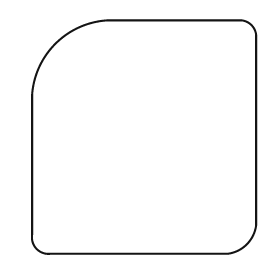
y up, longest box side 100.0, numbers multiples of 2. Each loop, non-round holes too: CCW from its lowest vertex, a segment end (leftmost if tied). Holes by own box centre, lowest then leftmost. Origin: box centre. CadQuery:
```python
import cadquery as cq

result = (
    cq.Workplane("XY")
    .moveTo(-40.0, -50.0)
    .lineTo(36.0, -50.0)
    .threePointArc((44.0, -46.0), (48.0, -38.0))
    .lineTo(48.0, 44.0)
    .threePointArc((46.0, 48.0), (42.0, 50.0))
    .lineTo(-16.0, 50.0)
    .threePointArc((-38.0, 40.0), (-48.0, 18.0))
    .lineTo(-48.0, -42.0)
    .threePointArc((-46.0, -48.0), (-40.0, -50.0))
    .close()
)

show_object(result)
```